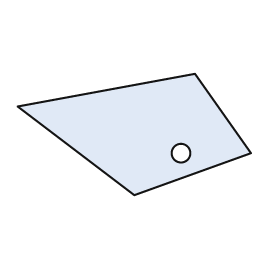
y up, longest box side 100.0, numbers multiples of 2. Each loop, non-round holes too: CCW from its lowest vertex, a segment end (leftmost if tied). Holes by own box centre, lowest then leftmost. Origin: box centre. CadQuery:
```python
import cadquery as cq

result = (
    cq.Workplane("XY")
    .moveTo(0.0, -26.0)
    .lineTo(50.0, -8.0)
    .lineTo(26.0, 26.0)
    .lineTo(-50.0, 12.0)
    .close()
    .moveTo(20.0, -8.0)
    .circle(4.0)
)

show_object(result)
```